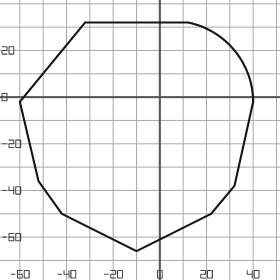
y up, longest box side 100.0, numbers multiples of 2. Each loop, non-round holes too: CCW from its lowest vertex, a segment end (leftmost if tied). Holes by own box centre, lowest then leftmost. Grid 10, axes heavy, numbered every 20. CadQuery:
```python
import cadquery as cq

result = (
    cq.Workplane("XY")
    .moveTo(-10.0, -66.0)
    .lineTo(22.0, -50.0)
    .lineTo(32.0, -38.0)
    .lineTo(40.0, -2.0)
    .threePointArc((32.0, 20.0), (12.0, 32.0))
    .lineTo(-32.0, 32.0)
    .lineTo(-60.0, -2.0)
    .lineTo(-52.0, -36.0)
    .lineTo(-42.0, -50.0)
    .close()
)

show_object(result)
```